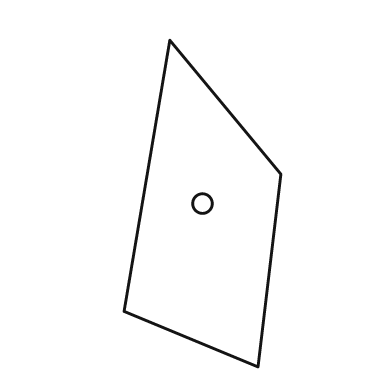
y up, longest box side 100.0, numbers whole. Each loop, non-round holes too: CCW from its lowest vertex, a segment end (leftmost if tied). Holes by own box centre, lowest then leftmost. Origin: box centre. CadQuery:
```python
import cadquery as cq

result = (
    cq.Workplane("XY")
    .moveTo(17.0, -50.0)
    .lineTo(24.0, 9.0)
    .lineTo(-10.0, 50.0)
    .lineTo(-24.0, -33.0)
    .close()
    .moveTo(0.0, 0.0)
    .circle(3.0)
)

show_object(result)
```